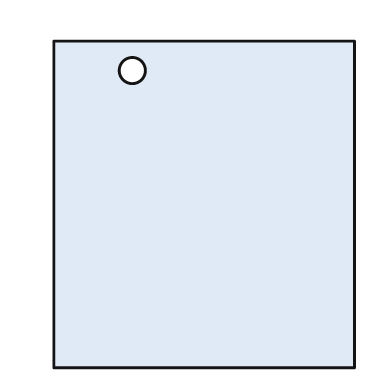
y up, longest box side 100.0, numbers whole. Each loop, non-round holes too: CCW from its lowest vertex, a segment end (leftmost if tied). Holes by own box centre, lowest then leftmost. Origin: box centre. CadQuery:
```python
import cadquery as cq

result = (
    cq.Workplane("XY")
    .moveTo(-46.0, -50.0)
    .lineTo(46.0, -50.0)
    .lineTo(46.0, 50.0)
    .lineTo(-46.0, 50.0)
    .close()
    .moveTo(-22.0, 41.0)
    .circle(4.0)
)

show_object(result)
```